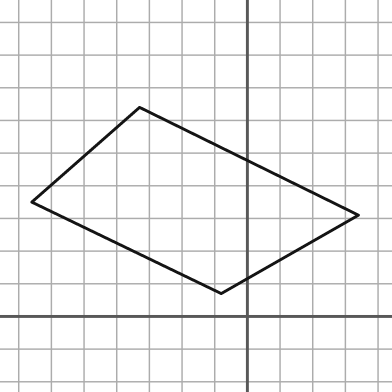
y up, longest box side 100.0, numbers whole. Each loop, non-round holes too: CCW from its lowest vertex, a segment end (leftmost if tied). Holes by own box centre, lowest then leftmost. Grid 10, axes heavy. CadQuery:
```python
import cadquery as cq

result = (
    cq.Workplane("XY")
    .moveTo(-8.0, 7.0)
    .lineTo(34.0, 31.0)
    .lineTo(-33.0, 64.0)
    .lineTo(-66.0, 35.0)
    .close()
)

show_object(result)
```